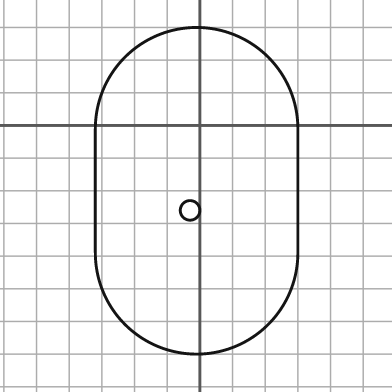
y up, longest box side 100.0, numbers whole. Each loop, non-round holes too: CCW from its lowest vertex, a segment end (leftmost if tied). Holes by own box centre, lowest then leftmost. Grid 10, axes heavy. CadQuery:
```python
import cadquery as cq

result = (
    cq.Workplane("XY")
    .moveTo(-32.0, -39.0)
    .threePointArc((-1.0, -70.0), (30.0, -39.0))
    .lineTo(30.0, -1.0)
    .threePointArc((-1.0, 30.0), (-32.0, -1.0))
    .close()
    .moveTo(-3.0, -26.0)
    .circle(3.0)
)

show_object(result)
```